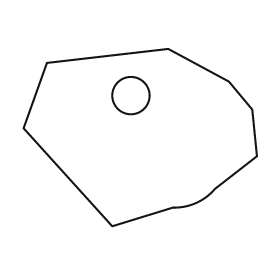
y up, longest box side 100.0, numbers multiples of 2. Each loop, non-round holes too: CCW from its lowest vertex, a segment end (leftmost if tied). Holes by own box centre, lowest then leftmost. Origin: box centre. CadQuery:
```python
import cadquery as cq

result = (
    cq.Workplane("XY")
    .moveTo(-12.0, -38.0)
    .lineTo(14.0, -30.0)
    .threePointArc((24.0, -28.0), (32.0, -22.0))
    .lineTo(50.0, -8.0)
    .lineTo(48.0, 12.0)
    .lineTo(38.0, 24.0)
    .lineTo(12.0, 38.0)
    .lineTo(-40.0, 32.0)
    .lineTo(-50.0, 4.0)
    .close()
    .moveTo(-4.0, 18.0)
    .circle(8.0)
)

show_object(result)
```